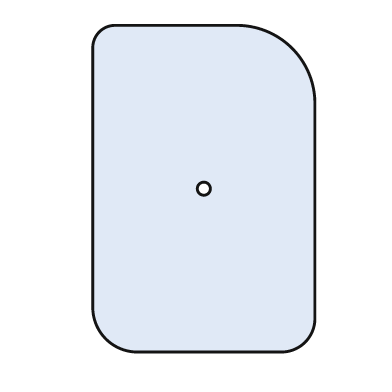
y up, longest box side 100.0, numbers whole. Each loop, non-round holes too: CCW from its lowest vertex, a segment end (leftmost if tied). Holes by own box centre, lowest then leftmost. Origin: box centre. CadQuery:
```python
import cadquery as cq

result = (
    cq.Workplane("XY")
    .moveTo(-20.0, -50.0)
    .lineTo(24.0, -50.0)
    .threePointArc((31.0, -47.0), (34.0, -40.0))
    .lineTo(34.0, 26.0)
    .threePointArc((27.0, 43.0), (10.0, 50.0))
    .lineTo(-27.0, 50.0)
    .threePointArc((-32.0, 48.0), (-34.0, 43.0))
    .lineTo(-34.0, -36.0)
    .threePointArc((-30.0, -46.0), (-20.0, -50.0))
    .close()
    .moveTo(0.0, 0.0)
    .circle(2.0)
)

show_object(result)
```